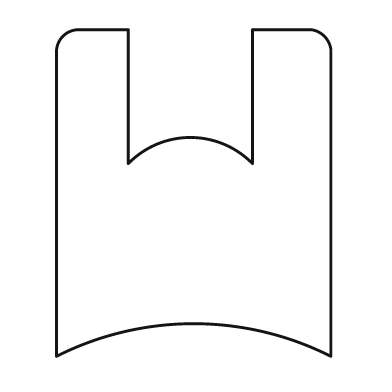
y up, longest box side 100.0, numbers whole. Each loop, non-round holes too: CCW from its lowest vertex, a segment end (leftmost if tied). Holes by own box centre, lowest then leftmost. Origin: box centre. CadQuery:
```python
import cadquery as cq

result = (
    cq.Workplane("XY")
    .moveTo(-42.0, -50.0)
    .threePointArc((0.0, -40.0), (42.0, -50.0))
    .lineTo(42.0, 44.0)
    .threePointArc((40.0, 48.0), (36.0, 50.0))
    .lineTo(18.0, 50.0)
    .lineTo(18.0, 9.0)
    .threePointArc((-1.0, 17.0), (-20.0, 9.0))
    .lineTo(-20.0, 50.0)
    .lineTo(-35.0, 50.0)
    .threePointArc((-40.0, 48.0), (-42.0, 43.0))
    .close()
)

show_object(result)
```